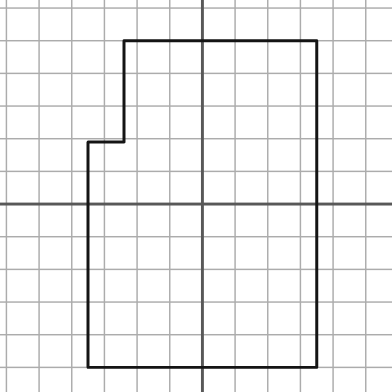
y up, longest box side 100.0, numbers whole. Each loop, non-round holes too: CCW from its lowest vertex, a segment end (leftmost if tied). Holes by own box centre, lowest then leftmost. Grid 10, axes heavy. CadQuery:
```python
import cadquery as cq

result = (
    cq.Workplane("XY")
    .moveTo(-35.0, -50.0)
    .lineTo(35.0, -50.0)
    .lineTo(35.0, 50.0)
    .lineTo(-24.0, 50.0)
    .lineTo(-24.0, 19.0)
    .lineTo(-35.0, 19.0)
    .close()
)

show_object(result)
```